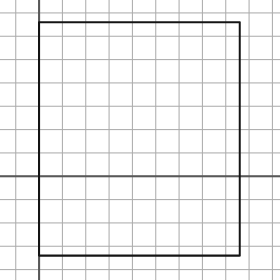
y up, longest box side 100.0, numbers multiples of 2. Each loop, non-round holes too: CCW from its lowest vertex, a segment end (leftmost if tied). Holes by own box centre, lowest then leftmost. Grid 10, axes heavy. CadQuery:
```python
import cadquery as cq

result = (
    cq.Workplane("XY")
    .moveTo(0.0, -34.0)
    .lineTo(86.0, -34.0)
    .lineTo(86.0, 66.0)
    .lineTo(0.0, 66.0)
    .close()
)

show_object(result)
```